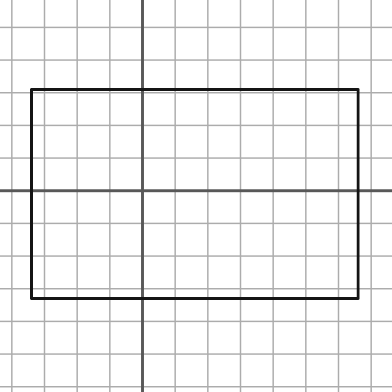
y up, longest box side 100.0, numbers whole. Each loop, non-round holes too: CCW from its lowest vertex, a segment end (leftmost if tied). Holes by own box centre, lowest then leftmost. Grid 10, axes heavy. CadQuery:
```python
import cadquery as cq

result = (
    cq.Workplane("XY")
    .moveTo(-34.0, -33.0)
    .lineTo(66.0, -33.0)
    .lineTo(66.0, 31.0)
    .lineTo(-34.0, 31.0)
    .close()
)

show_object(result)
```